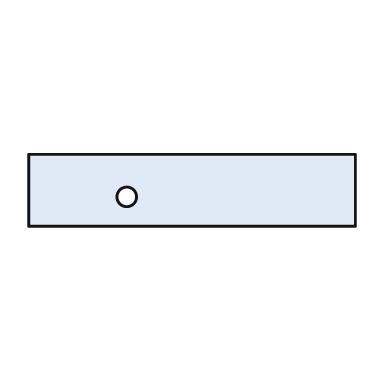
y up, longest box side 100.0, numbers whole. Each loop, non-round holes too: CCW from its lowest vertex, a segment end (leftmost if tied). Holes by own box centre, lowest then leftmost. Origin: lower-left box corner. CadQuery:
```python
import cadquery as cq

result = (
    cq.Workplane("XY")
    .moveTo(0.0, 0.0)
    .lineTo(100.0, 0.0)
    .lineTo(100.0, 22.0)
    .lineTo(0.0, 22.0)
    .close()
    .moveTo(30.0, 9.0)
    .circle(3.0)
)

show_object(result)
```